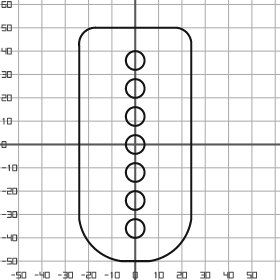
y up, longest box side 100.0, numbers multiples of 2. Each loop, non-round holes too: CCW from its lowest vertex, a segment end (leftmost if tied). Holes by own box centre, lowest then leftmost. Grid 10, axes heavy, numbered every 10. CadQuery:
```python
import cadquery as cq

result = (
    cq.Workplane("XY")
    .moveTo(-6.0, -50.0)
    .lineTo(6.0, -50.0)
    .threePointArc((18.0, -44.0), (24.0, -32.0))
    .lineTo(24.0, 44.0)
    .threePointArc((22.0, 48.0), (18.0, 50.0))
    .lineTo(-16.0, 50.0)
    .threePointArc((-22.0, 48.0), (-24.0, 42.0))
    .lineTo(-24.0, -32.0)
    .threePointArc((-18.0, -44.0), (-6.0, -50.0))
    .close()
    .moveTo(0.0, -36.0)
    .circle(4.0)
    .moveTo(0.0, -24.0)
    .circle(4.0)
    .moveTo(0.0, -12.0)
    .circle(4.0)
    .moveTo(0.0, 0.0)
    .circle(4.0)
    .moveTo(0.0, 12.0)
    .circle(4.0)
    .moveTo(0.0, 24.0)
    .circle(4.0)
    .moveTo(0.0, 36.0)
    .circle(4.0)
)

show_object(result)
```